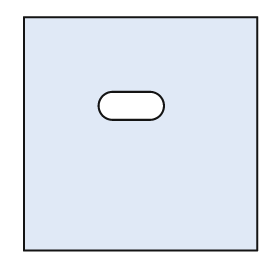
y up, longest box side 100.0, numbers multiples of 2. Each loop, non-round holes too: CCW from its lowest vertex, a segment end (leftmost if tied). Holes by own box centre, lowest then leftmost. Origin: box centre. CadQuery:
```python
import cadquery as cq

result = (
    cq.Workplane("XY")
    .moveTo(-50.0, -50.0)
    .lineTo(50.0, -50.0)
    .lineTo(50.0, 50.0)
    .lineTo(-50.0, 50.0)
    .close()
    .moveTo(-12.0, 6.0)
    .lineTo(4.0, 6.0)
    .threePointArc((10.0, 12.0), (4.0, 18.0))
    .lineTo(-12.0, 18.0)
    .threePointArc((-18.0, 12.0), (-12.0, 6.0))
    .close()
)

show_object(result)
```